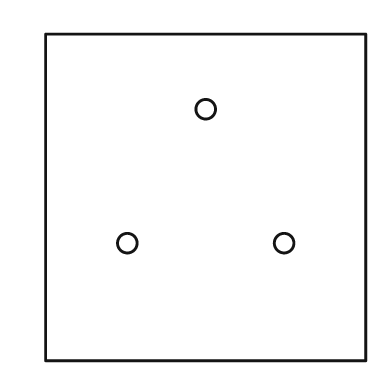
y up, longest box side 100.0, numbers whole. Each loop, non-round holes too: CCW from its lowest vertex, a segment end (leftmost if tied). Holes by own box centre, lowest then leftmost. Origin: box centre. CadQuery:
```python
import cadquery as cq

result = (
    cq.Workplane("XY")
    .moveTo(-49.0, -50.0)
    .lineTo(49.0, -50.0)
    .lineTo(49.0, 50.0)
    .lineTo(-49.0, 50.0)
    .close()
    .moveTo(-24.0, -14.0)
    .circle(3.0)
    .moveTo(24.0, -14.0)
    .circle(3.0)
    .moveTo(0.0, 27.0)
    .circle(3.0)
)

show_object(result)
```